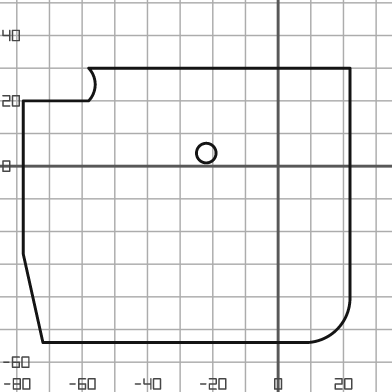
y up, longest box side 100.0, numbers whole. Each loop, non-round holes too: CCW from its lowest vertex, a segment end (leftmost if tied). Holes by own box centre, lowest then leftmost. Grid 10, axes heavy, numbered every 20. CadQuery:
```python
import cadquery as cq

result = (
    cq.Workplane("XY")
    .moveTo(-72.0, -54.0)
    .lineTo(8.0, -54.0)
    .threePointArc((18.0, -50.0), (22.0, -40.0))
    .lineTo(22.0, 30.0)
    .lineTo(-58.0, 30.0)
    .threePointArc((-56.0, 25.0), (-58.0, 20.0))
    .lineTo(-78.0, 20.0)
    .lineTo(-78.0, -27.0)
    .close()
    .moveTo(-22.0, 4.0)
    .circle(3.0)
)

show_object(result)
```